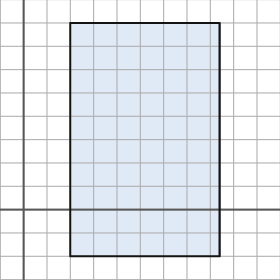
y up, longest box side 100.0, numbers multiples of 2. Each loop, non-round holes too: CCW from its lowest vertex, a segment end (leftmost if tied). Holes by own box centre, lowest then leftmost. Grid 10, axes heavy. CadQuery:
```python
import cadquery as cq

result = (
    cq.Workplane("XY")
    .moveTo(20.0, -20.0)
    .lineTo(84.0, -20.0)
    .lineTo(84.0, 80.0)
    .lineTo(20.0, 80.0)
    .close()
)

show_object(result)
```